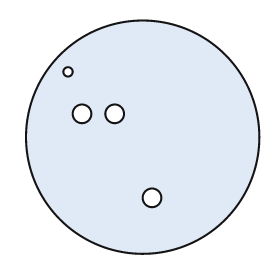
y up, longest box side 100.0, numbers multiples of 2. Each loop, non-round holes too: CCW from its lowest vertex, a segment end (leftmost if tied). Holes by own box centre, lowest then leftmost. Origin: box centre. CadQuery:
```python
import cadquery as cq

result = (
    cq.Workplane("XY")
    .moveTo(0.0, 0.0)
    .circle(50.0)
    .moveTo(4.0, -26.0)
    .circle(4.0)
    .moveTo(-26.0, 10.0)
    .circle(4.0)
    .moveTo(-12.0, 10.0)
    .circle(4.0)
    .moveTo(-32.0, 28.0)
    .circle(2.0)
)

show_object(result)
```